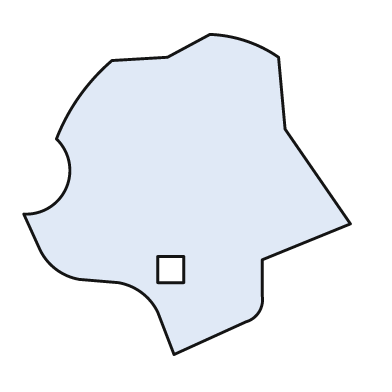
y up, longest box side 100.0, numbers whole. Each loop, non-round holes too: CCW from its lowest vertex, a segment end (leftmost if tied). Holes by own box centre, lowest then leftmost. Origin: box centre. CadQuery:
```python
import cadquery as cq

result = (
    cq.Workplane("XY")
    .moveTo(-4.0, -49.0)
    .lineTo(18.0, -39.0)
    .threePointArc((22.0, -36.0), (23.0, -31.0))
    .lineTo(23.0, -20.0)
    .lineTo(50.0, -9.0)
    .lineTo(30.0, 20.0)
    .lineTo(28.0, 42.0)
    .threePointArc((18.0, 47.0), (7.0, 49.0))
    .lineTo(-6.0, 42.0)
    .lineTo(-23.0, 41.0)
    .threePointArc((-33.0, 30.0), (-40.0, 17.0))
    .threePointArc((-37.0, 2.0), (-50.0, -6.0))
    .lineTo(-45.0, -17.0)
    .threePointArc((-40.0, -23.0), (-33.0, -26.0))
    .lineTo(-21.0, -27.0)
    .threePointArc((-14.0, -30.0), (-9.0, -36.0))
    .close()
    .moveTo(-9.0, -27.0)
    .lineTo(-1.0, -27.0)
    .lineTo(-1.0, -19.0)
    .lineTo(-9.0, -19.0)
    .close()
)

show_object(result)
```